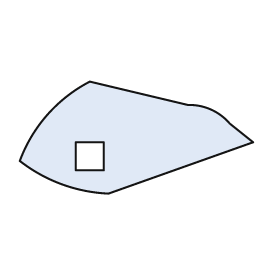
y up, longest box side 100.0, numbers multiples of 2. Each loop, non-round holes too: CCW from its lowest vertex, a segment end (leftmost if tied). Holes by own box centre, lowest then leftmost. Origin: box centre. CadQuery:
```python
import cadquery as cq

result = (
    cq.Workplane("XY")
    .moveTo(-12.0, -24.0)
    .lineTo(50.0, -2.0)
    .lineTo(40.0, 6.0)
    .threePointArc((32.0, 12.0), (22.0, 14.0))
    .lineTo(-20.0, 24.0)
    .threePointArc((-38.0, 10.0), (-50.0, -10.0))
    .threePointArc((-32.0, -20.0), (-12.0, -24.0))
    .close()
    .moveTo(-26.0, -14.0)
    .lineTo(-14.0, -14.0)
    .lineTo(-14.0, -2.0)
    .lineTo(-26.0, -2.0)
    .close()
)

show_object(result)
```